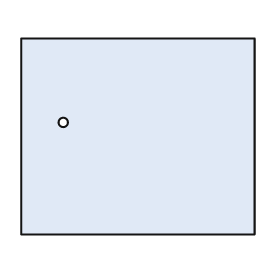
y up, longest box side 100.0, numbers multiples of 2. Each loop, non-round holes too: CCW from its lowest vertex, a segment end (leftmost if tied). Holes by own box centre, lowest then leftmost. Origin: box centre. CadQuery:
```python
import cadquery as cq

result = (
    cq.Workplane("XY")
    .moveTo(-50.0, -42.0)
    .lineTo(50.0, -42.0)
    .lineTo(50.0, 42.0)
    .lineTo(-50.0, 42.0)
    .close()
    .moveTo(-32.0, 6.0)
    .circle(2.0)
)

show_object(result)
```